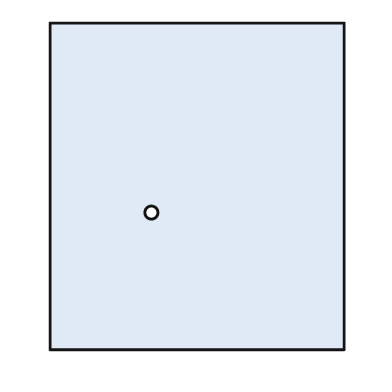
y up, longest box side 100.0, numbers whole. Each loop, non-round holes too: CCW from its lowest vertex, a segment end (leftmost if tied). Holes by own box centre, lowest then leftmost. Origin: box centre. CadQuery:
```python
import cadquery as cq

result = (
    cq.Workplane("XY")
    .moveTo(-45.0, -50.0)
    .lineTo(45.0, -50.0)
    .lineTo(45.0, 50.0)
    .lineTo(-45.0, 50.0)
    .close()
    .moveTo(-14.0, -8.0)
    .circle(2.0)
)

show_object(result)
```